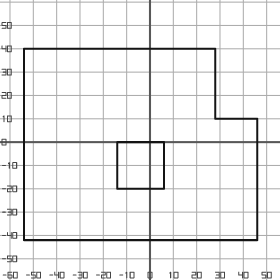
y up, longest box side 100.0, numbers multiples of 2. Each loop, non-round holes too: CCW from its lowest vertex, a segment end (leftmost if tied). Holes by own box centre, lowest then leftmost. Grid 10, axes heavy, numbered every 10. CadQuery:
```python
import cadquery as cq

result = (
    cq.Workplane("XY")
    .moveTo(-54.0, -42.0)
    .lineTo(46.0, -42.0)
    .lineTo(46.0, 10.0)
    .lineTo(28.0, 10.0)
    .lineTo(28.0, 40.0)
    .lineTo(-54.0, 40.0)
    .close()
    .moveTo(-14.0, -20.0)
    .lineTo(6.0, -20.0)
    .lineTo(6.0, 0.0)
    .lineTo(-14.0, 0.0)
    .close()
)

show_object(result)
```